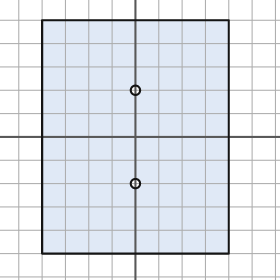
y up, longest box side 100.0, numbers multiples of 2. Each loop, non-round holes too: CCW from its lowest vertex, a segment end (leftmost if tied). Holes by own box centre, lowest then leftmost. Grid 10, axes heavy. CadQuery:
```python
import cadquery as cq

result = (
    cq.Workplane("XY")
    .moveTo(-40.0, -50.0)
    .lineTo(40.0, -50.0)
    .lineTo(40.0, 50.0)
    .lineTo(-40.0, 50.0)
    .close()
    .moveTo(0.0, -20.0)
    .circle(2.0)
    .moveTo(0.0, 20.0)
    .circle(2.0)
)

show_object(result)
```